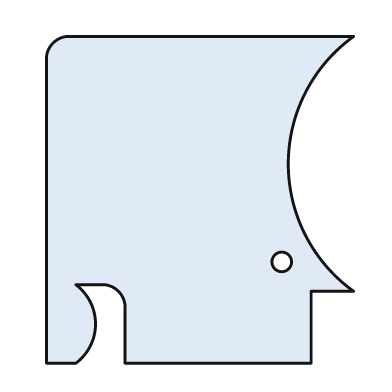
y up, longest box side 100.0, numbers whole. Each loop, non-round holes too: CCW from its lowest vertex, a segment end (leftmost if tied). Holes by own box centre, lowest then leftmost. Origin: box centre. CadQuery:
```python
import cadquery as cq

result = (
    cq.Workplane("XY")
    .moveTo(-47.0, -50.0)
    .lineTo(-38.0, -50.0)
    .threePointArc((-32.0, -38.0), (-38.0, -26.0))
    .lineTo(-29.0, -26.0)
    .threePointArc((-25.0, -28.0), (-23.0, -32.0))
    .lineTo(-23.0, -50.0)
    .lineTo(34.0, -50.0)
    .lineTo(34.0, -28.0)
    .lineTo(47.0, -28.0)
    .threePointArc((27.0, 11.0), (47.0, 50.0))
    .lineTo(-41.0, 50.0)
    .threePointArc((-45.0, 48.0), (-47.0, 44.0))
    .close()
    .moveTo(25.0, -19.0)
    .circle(3.0)
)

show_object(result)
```